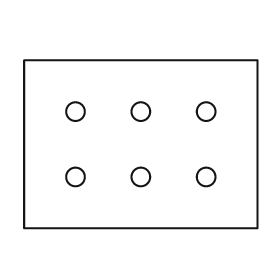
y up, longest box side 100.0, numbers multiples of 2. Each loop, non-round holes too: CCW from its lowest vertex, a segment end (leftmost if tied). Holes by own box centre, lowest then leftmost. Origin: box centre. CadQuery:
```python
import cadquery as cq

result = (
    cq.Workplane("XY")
    .moveTo(-50.0, -36.0)
    .lineTo(50.0, -36.0)
    .lineTo(50.0, 36.0)
    .lineTo(-50.0, 36.0)
    .close()
    .moveTo(-28.0, -14.0)
    .circle(4.0)
    .moveTo(0.0, -14.0)
    .circle(4.0)
    .moveTo(28.0, -14.0)
    .circle(4.0)
    .moveTo(-28.0, 14.0)
    .circle(4.0)
    .moveTo(0.0, 14.0)
    .circle(4.0)
    .moveTo(28.0, 14.0)
    .circle(4.0)
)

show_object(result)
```